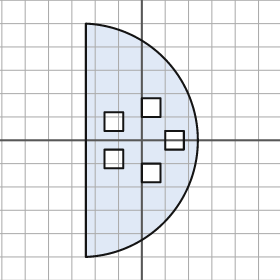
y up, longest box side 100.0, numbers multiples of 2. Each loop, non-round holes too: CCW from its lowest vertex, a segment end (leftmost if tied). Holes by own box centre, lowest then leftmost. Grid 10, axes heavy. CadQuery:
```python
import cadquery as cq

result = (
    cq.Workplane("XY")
    .moveTo(-24.0, -50.0)
    .threePointArc((24.0, 0.0), (-24.0, 50.0))
    .close()
    .moveTo(0.0, -18.0)
    .lineTo(8.0, -18.0)
    .lineTo(8.0, -10.0)
    .lineTo(0.0, -10.0)
    .close()
    .moveTo(-16.0, -12.0)
    .lineTo(-8.0, -12.0)
    .lineTo(-8.0, -4.0)
    .lineTo(-16.0, -4.0)
    .close()
    .moveTo(10.0, -4.0)
    .lineTo(18.0, -4.0)
    .lineTo(18.0, 4.0)
    .lineTo(10.0, 4.0)
    .close()
    .moveTo(-16.0, 4.0)
    .lineTo(-8.0, 4.0)
    .lineTo(-8.0, 12.0)
    .lineTo(-16.0, 12.0)
    .close()
    .moveTo(0.0, 10.0)
    .lineTo(8.0, 10.0)
    .lineTo(8.0, 18.0)
    .lineTo(0.0, 18.0)
    .close()
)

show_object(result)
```